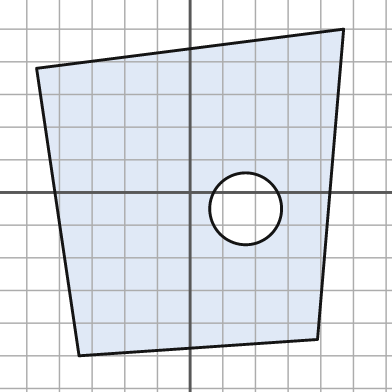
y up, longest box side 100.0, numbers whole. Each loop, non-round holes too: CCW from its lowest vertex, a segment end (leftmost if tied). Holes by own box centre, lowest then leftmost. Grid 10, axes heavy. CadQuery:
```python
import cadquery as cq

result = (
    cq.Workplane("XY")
    .moveTo(-34.0, -50.0)
    .lineTo(39.0, -45.0)
    .lineTo(47.0, 50.0)
    .lineTo(-47.0, 38.0)
    .close()
    .moveTo(17.0, -5.0)
    .circle(11.0)
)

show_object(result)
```